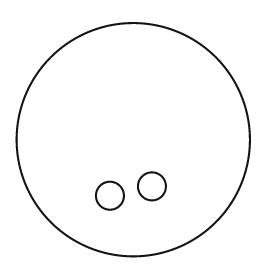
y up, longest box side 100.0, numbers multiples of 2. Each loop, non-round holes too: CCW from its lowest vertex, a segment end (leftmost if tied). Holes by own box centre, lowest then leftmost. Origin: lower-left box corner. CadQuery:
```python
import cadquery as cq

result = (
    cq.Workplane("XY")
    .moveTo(50.0, 50.0)
    .circle(50.0)
    .moveTo(40.0, 26.0)
    .circle(6.0)
    .moveTo(58.0, 30.0)
    .circle(6.0)
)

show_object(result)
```